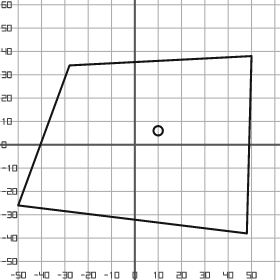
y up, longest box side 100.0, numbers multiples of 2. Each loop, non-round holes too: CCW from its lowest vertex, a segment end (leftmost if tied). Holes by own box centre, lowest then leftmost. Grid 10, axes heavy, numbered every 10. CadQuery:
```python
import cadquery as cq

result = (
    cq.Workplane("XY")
    .moveTo(48.0, -38.0)
    .lineTo(50.0, 38.0)
    .lineTo(-28.0, 34.0)
    .lineTo(-50.0, -26.0)
    .close()
    .moveTo(10.0, 6.0)
    .circle(2.0)
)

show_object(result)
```